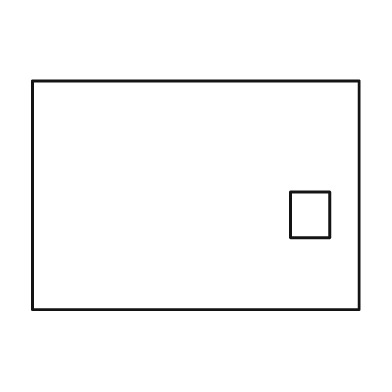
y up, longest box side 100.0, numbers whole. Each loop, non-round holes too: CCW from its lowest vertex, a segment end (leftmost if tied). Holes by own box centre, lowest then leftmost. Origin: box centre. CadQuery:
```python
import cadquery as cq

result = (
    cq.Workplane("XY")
    .moveTo(-50.0, -35.0)
    .lineTo(50.0, -35.0)
    .lineTo(50.0, 35.0)
    .lineTo(-50.0, 35.0)
    .close()
    .moveTo(29.0, -13.0)
    .lineTo(41.0, -13.0)
    .lineTo(41.0, 1.0)
    .lineTo(29.0, 1.0)
    .close()
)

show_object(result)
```